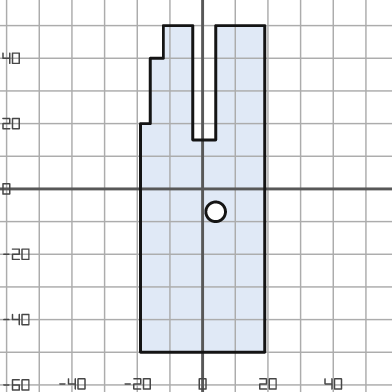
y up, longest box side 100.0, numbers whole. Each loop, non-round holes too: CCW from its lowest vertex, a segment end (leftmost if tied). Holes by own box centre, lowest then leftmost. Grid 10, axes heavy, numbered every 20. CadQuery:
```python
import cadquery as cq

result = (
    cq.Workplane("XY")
    .moveTo(-19.0, -50.0)
    .lineTo(19.0, -50.0)
    .lineTo(19.0, 50.0)
    .lineTo(4.0, 50.0)
    .lineTo(4.0, 15.0)
    .lineTo(-3.0, 15.0)
    .lineTo(-3.0, 50.0)
    .lineTo(-12.0, 50.0)
    .lineTo(-12.0, 40.0)
    .lineTo(-16.0, 40.0)
    .lineTo(-16.0, 20.0)
    .lineTo(-19.0, 20.0)
    .close()
    .moveTo(4.0, -7.0)
    .circle(3.0)
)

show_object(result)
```